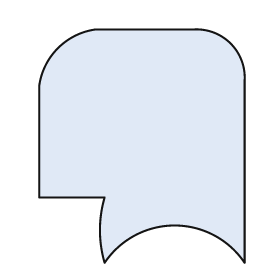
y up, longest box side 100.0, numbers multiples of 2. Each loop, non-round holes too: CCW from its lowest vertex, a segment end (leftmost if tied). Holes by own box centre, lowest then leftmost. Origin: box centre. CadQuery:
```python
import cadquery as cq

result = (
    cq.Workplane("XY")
    .moveTo(-16.0, -50.0)
    .threePointArc((14.0, -34.0), (44.0, -50.0))
    .lineTo(44.0, 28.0)
    .threePointArc((38.0, 44.0), (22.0, 50.0))
    .lineTo(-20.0, 50.0)
    .threePointArc((-36.0, 42.0), (-44.0, 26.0))
    .lineTo(-44.0, -22.0)
    .lineTo(-16.0, -22.0)
    .threePointArc((-18.0, -36.0), (-16.0, -50.0))
    .close()
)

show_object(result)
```